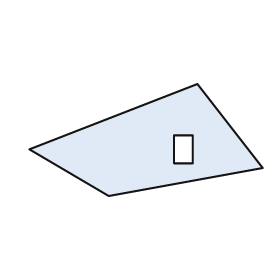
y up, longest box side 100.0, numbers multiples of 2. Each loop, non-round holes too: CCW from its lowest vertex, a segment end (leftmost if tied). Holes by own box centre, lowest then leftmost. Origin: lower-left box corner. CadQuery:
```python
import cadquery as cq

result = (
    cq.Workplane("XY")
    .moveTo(34.0, 0.0)
    .lineTo(100.0, 12.0)
    .lineTo(72.0, 48.0)
    .lineTo(0.0, 20.0)
    .close()
    .moveTo(62.0, 14.0)
    .lineTo(70.0, 14.0)
    .lineTo(70.0, 26.0)
    .lineTo(62.0, 26.0)
    .close()
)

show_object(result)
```